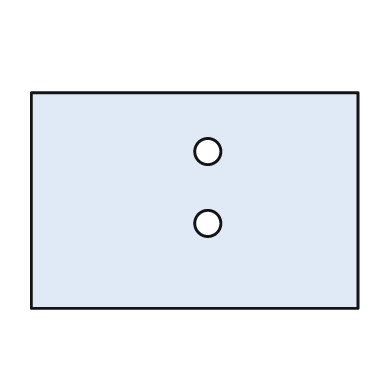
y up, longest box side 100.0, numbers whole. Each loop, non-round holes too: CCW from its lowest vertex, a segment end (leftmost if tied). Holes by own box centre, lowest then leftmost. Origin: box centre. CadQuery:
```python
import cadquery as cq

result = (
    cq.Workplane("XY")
    .moveTo(-50.0, -33.0)
    .lineTo(50.0, -33.0)
    .lineTo(50.0, 33.0)
    .lineTo(-50.0, 33.0)
    .close()
    .moveTo(4.0, -7.0)
    .circle(4.0)
    .moveTo(4.0, 15.0)
    .circle(4.0)
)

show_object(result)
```